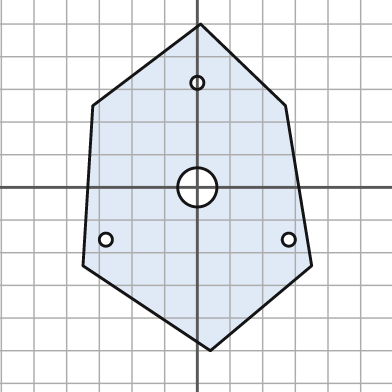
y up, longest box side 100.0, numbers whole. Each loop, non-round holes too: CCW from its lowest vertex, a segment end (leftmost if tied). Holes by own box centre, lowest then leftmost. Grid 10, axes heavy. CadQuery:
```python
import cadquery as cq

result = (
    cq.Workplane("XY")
    .moveTo(4.0, -50.0)
    .lineTo(35.0, -24.0)
    .lineTo(27.0, 25.0)
    .lineTo(1.0, 50.0)
    .lineTo(-32.0, 25.0)
    .lineTo(-35.0, -24.0)
    .close()
    .moveTo(-28.0, -16.0)
    .circle(2.0)
    .moveTo(28.0, -16.0)
    .circle(2.0)
    .moveTo(0.0, 0.0)
    .circle(6.0)
    .moveTo(0.0, 32.0)
    .circle(2.0)
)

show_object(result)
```